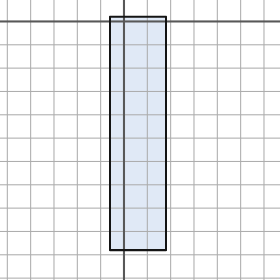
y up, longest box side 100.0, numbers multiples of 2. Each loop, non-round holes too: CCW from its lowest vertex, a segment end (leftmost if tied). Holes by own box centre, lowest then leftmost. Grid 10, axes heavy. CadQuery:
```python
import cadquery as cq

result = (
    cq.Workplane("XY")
    .moveTo(-6.0, -98.0)
    .lineTo(18.0, -98.0)
    .lineTo(18.0, 2.0)
    .lineTo(-6.0, 2.0)
    .close()
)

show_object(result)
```